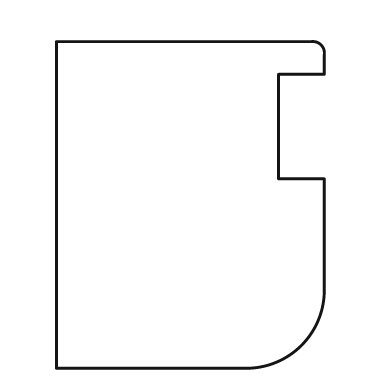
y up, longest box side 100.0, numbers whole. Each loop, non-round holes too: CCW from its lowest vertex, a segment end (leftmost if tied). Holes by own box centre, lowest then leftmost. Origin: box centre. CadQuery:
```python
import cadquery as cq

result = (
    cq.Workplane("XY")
    .moveTo(-41.0, -50.0)
    .lineTo(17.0, -50.0)
    .threePointArc((34.0, -43.0), (41.0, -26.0))
    .lineTo(41.0, 8.0)
    .lineTo(27.0, 8.0)
    .lineTo(27.0, 40.0)
    .lineTo(41.0, 40.0)
    .lineTo(41.0, 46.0)
    .threePointArc((40.0, 49.0), (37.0, 50.0))
    .lineTo(-41.0, 50.0)
    .close()
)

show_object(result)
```